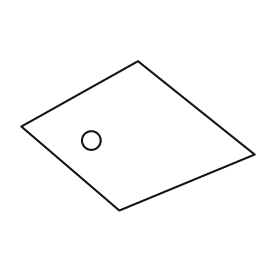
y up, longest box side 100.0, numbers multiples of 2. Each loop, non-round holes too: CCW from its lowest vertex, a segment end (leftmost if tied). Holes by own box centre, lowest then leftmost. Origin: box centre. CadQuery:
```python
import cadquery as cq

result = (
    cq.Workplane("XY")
    .moveTo(-8.0, -32.0)
    .lineTo(50.0, -8.0)
    .lineTo(0.0, 32.0)
    .lineTo(-50.0, 4.0)
    .close()
    .moveTo(-20.0, -2.0)
    .circle(4.0)
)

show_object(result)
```